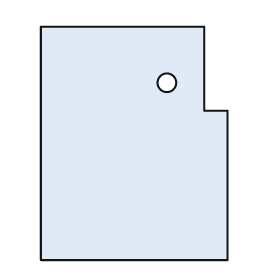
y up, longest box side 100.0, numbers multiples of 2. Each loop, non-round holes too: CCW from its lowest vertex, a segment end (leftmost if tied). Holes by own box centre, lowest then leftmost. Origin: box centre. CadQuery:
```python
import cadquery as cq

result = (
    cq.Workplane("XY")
    .moveTo(-40.0, -50.0)
    .lineTo(40.0, -50.0)
    .lineTo(40.0, 14.0)
    .lineTo(30.0, 14.0)
    .lineTo(30.0, 50.0)
    .lineTo(-40.0, 50.0)
    .close()
    .moveTo(14.0, 26.0)
    .circle(4.0)
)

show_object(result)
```